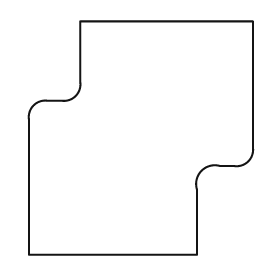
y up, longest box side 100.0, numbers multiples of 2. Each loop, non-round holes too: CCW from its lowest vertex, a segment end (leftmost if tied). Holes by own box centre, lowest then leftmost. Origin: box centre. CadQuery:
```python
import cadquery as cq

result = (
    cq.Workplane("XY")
    .moveTo(-48.0, -50.0)
    .lineTo(24.0, -50.0)
    .lineTo(24.0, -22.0)
    .threePointArc((26.0, -14.0), (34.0, -12.0))
    .lineTo(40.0, -12.0)
    .threePointArc((46.0, -10.0), (48.0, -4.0))
    .lineTo(48.0, 50.0)
    .lineTo(-26.0, 50.0)
    .lineTo(-26.0, 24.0)
    .threePointArc((-28.0, 18.0), (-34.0, 16.0))
    .lineTo(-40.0, 16.0)
    .threePointArc((-46.0, 14.0), (-48.0, 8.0))
    .close()
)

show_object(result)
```